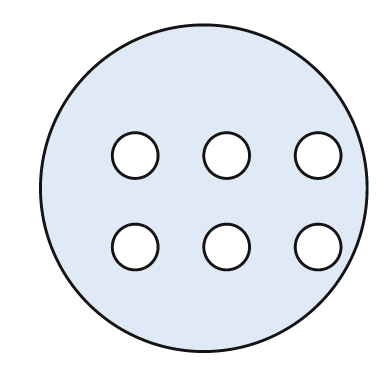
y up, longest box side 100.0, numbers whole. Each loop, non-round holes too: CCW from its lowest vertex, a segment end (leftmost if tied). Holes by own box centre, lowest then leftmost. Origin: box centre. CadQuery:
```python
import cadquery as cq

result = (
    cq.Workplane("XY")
    .moveTo(0.0, 0.0)
    .circle(50.0)
    .moveTo(-21.0, -18.0)
    .circle(7.0)
    .moveTo(7.0, -18.0)
    .circle(7.0)
    .moveTo(35.0, -18.0)
    .circle(7.0)
    .moveTo(-21.0, 10.0)
    .circle(7.0)
    .moveTo(7.0, 10.0)
    .circle(7.0)
    .moveTo(35.0, 10.0)
    .circle(7.0)
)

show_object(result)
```